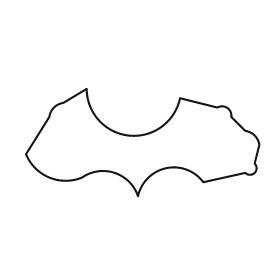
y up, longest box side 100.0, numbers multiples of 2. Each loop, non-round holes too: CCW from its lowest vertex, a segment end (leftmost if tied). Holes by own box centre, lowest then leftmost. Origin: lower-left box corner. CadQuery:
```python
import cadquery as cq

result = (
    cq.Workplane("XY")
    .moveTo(48.0, 0.0)
    .threePointArc((60.0, 12.0), (76.0, 6.0))
    .lineTo(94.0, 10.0)
    .threePointArc((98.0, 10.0), (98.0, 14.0))
    .lineTo(100.0, 22.0)
    .threePointArc((98.0, 26.0), (94.0, 28.0))
    .lineTo(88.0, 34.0)
    .threePointArc((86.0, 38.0), (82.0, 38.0))
    .lineTo(66.0, 42.0)
    .threePointArc((44.0, 26.0), (26.0, 46.0))
    .lineTo(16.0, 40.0)
    .threePointArc((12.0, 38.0), (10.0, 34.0))
    .lineTo(0.0, 18.0)
    .threePointArc((10.0, 8.0), (24.0, 8.0))
    .threePointArc((38.0, 10.0), (48.0, 0.0))
    .close()
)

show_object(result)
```